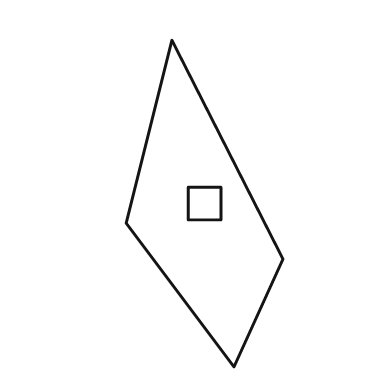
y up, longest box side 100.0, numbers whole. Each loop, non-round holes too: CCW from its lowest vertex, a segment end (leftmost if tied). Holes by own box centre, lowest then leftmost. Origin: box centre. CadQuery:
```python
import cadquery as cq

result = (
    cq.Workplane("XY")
    .moveTo(9.0, -50.0)
    .lineTo(24.0, -17.0)
    .lineTo(-10.0, 50.0)
    .lineTo(-24.0, -6.0)
    .close()
    .moveTo(-5.0, -5.0)
    .lineTo(5.0, -5.0)
    .lineTo(5.0, 5.0)
    .lineTo(-5.0, 5.0)
    .close()
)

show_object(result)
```